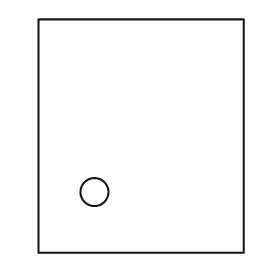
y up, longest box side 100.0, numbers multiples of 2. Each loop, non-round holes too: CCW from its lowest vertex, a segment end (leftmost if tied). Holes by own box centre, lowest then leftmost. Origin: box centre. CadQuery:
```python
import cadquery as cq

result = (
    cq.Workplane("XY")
    .moveTo(-44.0, -50.0)
    .lineTo(44.0, -50.0)
    .lineTo(44.0, 50.0)
    .lineTo(-44.0, 50.0)
    .close()
    .moveTo(-20.0, -24.0)
    .circle(6.0)
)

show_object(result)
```